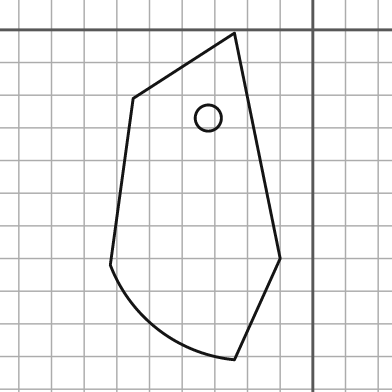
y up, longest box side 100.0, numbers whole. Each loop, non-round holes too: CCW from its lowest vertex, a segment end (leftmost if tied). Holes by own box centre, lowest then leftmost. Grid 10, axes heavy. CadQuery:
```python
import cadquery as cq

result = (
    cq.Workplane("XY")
    .moveTo(-24.0, -101.0)
    .lineTo(-10.0, -70.0)
    .lineTo(-24.0, -1.0)
    .lineTo(-55.0, -21.0)
    .lineTo(-62.0, -72.0)
    .threePointArc((-47.0, -92.0), (-24.0, -101.0))
    .close()
    .moveTo(-32.0, -27.0)
    .circle(4.0)
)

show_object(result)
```